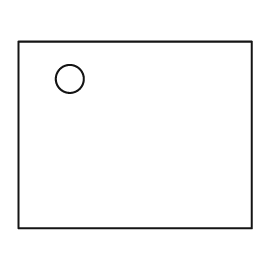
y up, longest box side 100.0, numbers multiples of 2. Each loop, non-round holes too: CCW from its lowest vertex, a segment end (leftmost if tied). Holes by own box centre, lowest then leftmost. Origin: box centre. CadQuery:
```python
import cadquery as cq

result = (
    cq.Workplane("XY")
    .moveTo(-50.0, -40.0)
    .lineTo(50.0, -40.0)
    .lineTo(50.0, 40.0)
    .lineTo(-50.0, 40.0)
    .close()
    .moveTo(-28.0, 24.0)
    .circle(6.0)
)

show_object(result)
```